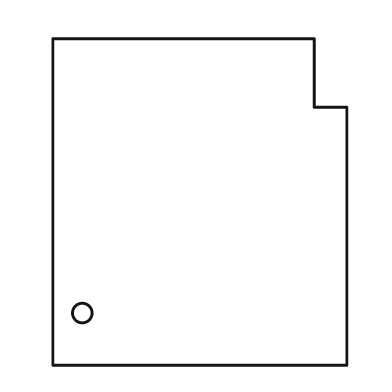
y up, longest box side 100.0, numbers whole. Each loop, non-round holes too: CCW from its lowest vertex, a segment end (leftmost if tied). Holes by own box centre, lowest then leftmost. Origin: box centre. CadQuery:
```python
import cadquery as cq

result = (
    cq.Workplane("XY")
    .moveTo(-45.0, -50.0)
    .lineTo(45.0, -50.0)
    .lineTo(45.0, 29.0)
    .lineTo(35.0, 29.0)
    .lineTo(35.0, 50.0)
    .lineTo(-45.0, 50.0)
    .close()
    .moveTo(-36.0, -34.0)
    .circle(3.0)
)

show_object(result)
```